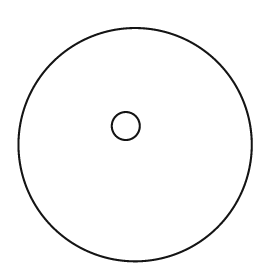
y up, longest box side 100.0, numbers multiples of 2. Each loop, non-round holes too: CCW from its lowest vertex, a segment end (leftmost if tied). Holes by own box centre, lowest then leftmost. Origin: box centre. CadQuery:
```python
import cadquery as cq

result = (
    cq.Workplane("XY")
    .moveTo(0.0, 0.0)
    .circle(50.0)
    .moveTo(-4.0, 8.0)
    .circle(6.0)
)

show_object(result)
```